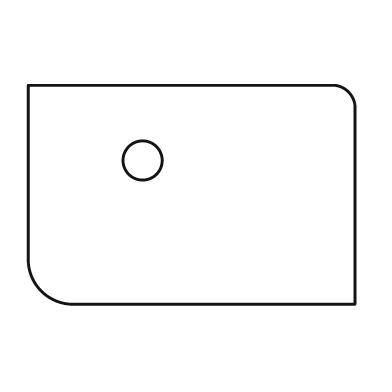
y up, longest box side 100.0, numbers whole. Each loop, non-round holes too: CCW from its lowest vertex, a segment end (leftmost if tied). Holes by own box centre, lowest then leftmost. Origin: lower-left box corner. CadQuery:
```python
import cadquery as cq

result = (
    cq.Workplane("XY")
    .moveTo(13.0, 0.0)
    .lineTo(100.0, 0.0)
    .lineTo(100.0, 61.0)
    .threePointArc((98.0, 65.0), (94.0, 67.0))
    .lineTo(0.0, 67.0)
    .lineTo(0.0, 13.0)
    .threePointArc((4.0, 4.0), (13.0, 0.0))
    .close()
    .moveTo(35.0, 44.0)
    .circle(6.0)
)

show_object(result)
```